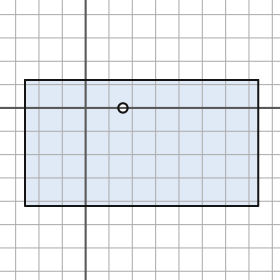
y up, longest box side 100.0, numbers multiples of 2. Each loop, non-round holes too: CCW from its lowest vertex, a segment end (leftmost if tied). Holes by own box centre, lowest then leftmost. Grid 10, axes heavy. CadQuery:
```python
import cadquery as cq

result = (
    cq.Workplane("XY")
    .moveTo(-26.0, -42.0)
    .lineTo(74.0, -42.0)
    .lineTo(74.0, 12.0)
    .lineTo(-26.0, 12.0)
    .close()
    .moveTo(16.0, 0.0)
    .circle(2.0)
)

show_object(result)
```